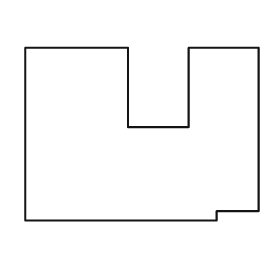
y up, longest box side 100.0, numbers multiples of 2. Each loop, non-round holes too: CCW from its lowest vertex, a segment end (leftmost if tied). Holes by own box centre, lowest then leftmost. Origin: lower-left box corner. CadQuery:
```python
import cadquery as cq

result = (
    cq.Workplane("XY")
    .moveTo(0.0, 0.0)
    .lineTo(82.0, 0.0)
    .lineTo(82.0, 4.0)
    .lineTo(100.0, 4.0)
    .lineTo(100.0, 74.0)
    .lineTo(70.0, 74.0)
    .lineTo(70.0, 40.0)
    .lineTo(44.0, 40.0)
    .lineTo(44.0, 74.0)
    .lineTo(0.0, 74.0)
    .close()
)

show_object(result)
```